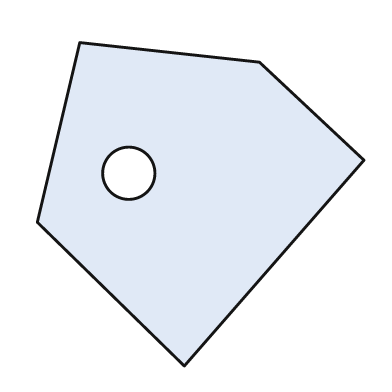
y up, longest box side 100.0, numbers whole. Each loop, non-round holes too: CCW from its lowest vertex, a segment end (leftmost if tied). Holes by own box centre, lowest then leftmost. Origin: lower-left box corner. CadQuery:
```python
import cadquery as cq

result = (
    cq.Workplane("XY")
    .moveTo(45.0, 0.0)
    .lineTo(100.0, 63.0)
    .lineTo(68.0, 93.0)
    .lineTo(13.0, 99.0)
    .lineTo(0.0, 44.0)
    .close()
    .moveTo(28.0, 59.0)
    .circle(8.0)
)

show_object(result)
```